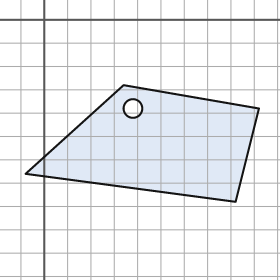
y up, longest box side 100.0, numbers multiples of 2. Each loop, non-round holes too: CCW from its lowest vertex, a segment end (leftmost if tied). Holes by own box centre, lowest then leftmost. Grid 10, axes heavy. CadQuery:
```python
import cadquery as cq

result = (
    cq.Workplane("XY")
    .moveTo(82.0, -78.0)
    .lineTo(92.0, -38.0)
    .lineTo(34.0, -28.0)
    .lineTo(-8.0, -66.0)
    .close()
    .moveTo(38.0, -38.0)
    .circle(4.0)
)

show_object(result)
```